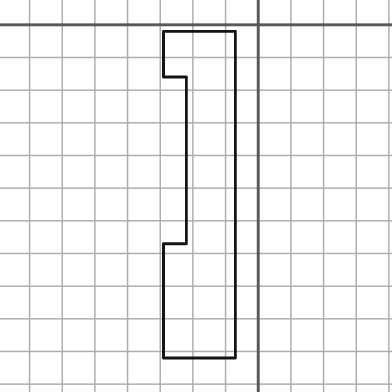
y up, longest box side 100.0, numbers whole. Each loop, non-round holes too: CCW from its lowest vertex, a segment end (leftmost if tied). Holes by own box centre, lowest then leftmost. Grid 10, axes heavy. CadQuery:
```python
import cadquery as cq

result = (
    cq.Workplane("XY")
    .moveTo(-29.0, -102.0)
    .lineTo(-7.0, -102.0)
    .lineTo(-7.0, -2.0)
    .lineTo(-29.0, -2.0)
    .lineTo(-29.0, -16.0)
    .lineTo(-22.0, -16.0)
    .lineTo(-22.0, -67.0)
    .lineTo(-29.0, -67.0)
    .close()
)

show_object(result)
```